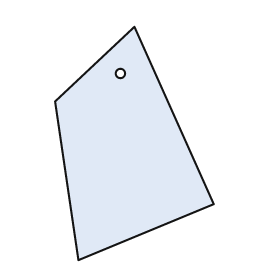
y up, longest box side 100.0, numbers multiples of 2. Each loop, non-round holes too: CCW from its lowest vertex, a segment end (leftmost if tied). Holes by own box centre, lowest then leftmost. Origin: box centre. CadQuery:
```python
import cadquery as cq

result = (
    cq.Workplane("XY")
    .moveTo(-24.0, -50.0)
    .lineTo(34.0, -26.0)
    .lineTo(0.0, 50.0)
    .lineTo(-34.0, 18.0)
    .close()
    .moveTo(-6.0, 30.0)
    .circle(2.0)
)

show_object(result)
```